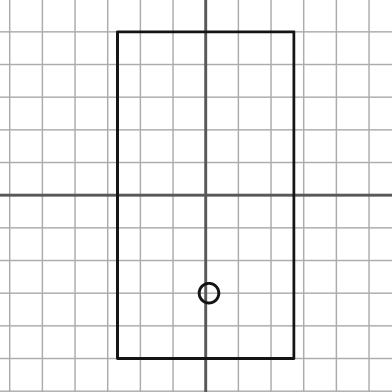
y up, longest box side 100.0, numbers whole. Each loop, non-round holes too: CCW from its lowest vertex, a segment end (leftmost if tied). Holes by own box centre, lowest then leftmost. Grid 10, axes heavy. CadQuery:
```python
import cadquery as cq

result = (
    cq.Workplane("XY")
    .moveTo(-27.0, -50.0)
    .lineTo(27.0, -50.0)
    .lineTo(27.0, 50.0)
    .lineTo(-27.0, 50.0)
    .close()
    .moveTo(1.0, -30.0)
    .circle(3.0)
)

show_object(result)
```